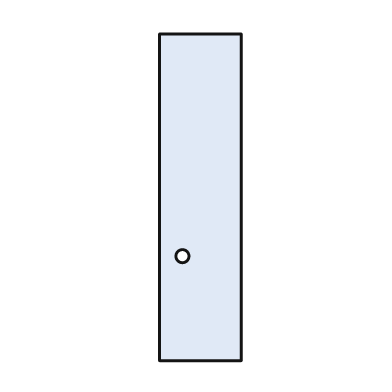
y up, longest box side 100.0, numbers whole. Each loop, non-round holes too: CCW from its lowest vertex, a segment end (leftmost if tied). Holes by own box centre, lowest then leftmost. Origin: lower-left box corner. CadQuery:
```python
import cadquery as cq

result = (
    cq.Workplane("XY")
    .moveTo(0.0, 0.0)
    .lineTo(25.0, 0.0)
    .lineTo(25.0, 100.0)
    .lineTo(0.0, 100.0)
    .close()
    .moveTo(7.0, 32.0)
    .circle(2.0)
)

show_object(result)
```